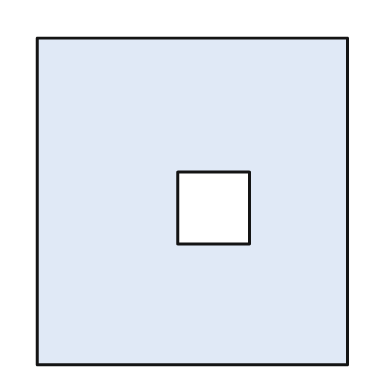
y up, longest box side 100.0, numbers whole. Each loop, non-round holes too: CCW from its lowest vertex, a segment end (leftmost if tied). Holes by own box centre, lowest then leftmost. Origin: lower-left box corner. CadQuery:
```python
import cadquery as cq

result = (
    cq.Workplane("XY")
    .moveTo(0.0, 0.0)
    .lineTo(95.0, 0.0)
    .lineTo(95.0, 100.0)
    .lineTo(0.0, 100.0)
    .close()
    .moveTo(43.0, 37.0)
    .lineTo(65.0, 37.0)
    .lineTo(65.0, 59.0)
    .lineTo(43.0, 59.0)
    .close()
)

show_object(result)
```